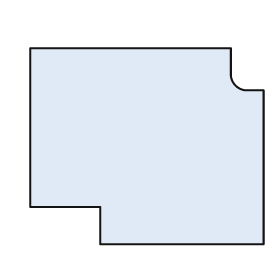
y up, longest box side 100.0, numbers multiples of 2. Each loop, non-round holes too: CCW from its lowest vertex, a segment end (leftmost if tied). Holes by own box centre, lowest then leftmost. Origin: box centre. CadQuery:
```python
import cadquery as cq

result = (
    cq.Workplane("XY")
    .moveTo(-20.0, -42.0)
    .lineTo(50.0, -42.0)
    .lineTo(50.0, 24.0)
    .lineTo(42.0, 24.0)
    .threePointArc((38.0, 26.0), (36.0, 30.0))
    .lineTo(36.0, 42.0)
    .lineTo(-50.0, 42.0)
    .lineTo(-50.0, -26.0)
    .lineTo(-20.0, -26.0)
    .close()
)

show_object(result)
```